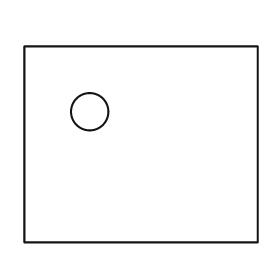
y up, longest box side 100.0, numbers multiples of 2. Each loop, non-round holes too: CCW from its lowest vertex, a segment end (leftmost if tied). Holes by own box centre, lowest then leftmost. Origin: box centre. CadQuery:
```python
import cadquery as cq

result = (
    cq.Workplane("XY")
    .moveTo(-50.0, -42.0)
    .lineTo(50.0, -42.0)
    .lineTo(50.0, 42.0)
    .lineTo(-50.0, 42.0)
    .close()
    .moveTo(-22.0, 14.0)
    .circle(8.0)
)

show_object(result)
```